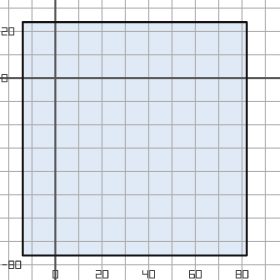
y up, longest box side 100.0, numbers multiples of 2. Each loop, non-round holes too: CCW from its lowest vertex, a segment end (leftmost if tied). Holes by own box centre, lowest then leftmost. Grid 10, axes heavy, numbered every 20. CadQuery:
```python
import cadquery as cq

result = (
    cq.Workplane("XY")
    .moveTo(-14.0, -76.0)
    .lineTo(82.0, -76.0)
    .lineTo(82.0, 24.0)
    .lineTo(-14.0, 24.0)
    .close()
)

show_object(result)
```